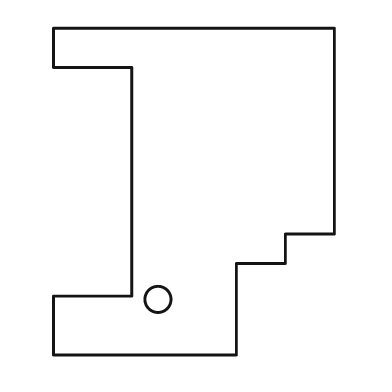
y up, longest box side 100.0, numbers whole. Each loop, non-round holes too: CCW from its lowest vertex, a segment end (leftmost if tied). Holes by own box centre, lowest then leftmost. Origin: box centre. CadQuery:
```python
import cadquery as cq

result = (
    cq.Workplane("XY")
    .moveTo(-43.0, -50.0)
    .lineTo(13.0, -50.0)
    .lineTo(13.0, -22.0)
    .lineTo(28.0, -22.0)
    .lineTo(28.0, -13.0)
    .lineTo(43.0, -13.0)
    .lineTo(43.0, 50.0)
    .lineTo(-43.0, 50.0)
    .lineTo(-43.0, 38.0)
    .lineTo(-19.0, 38.0)
    .lineTo(-19.0, -32.0)
    .lineTo(-43.0, -32.0)
    .close()
    .moveTo(-11.0, -33.0)
    .circle(4.0)
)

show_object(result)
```